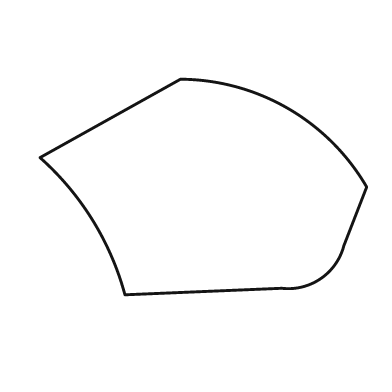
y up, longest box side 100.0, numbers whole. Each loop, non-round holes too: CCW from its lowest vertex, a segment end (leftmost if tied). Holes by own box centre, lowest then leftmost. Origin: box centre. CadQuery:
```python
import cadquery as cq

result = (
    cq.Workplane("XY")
    .moveTo(-24.0, -33.0)
    .lineTo(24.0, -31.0)
    .threePointArc((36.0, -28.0), (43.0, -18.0))
    .lineTo(50.0, 0.0)
    .threePointArc((26.0, 24.0), (-7.0, 33.0))
    .lineTo(-50.0, 9.0)
    .threePointArc((-34.0, -10.0), (-24.0, -33.0))
    .close()
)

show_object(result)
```